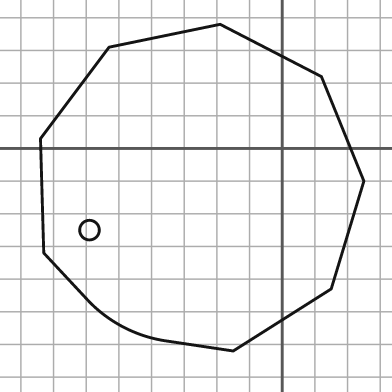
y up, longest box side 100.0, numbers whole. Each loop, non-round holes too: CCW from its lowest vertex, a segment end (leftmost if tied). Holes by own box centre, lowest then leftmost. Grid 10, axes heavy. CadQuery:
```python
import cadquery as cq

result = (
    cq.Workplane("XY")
    .moveTo(-15.0, -62.0)
    .lineTo(15.0, -43.0)
    .lineTo(25.0, -10.0)
    .lineTo(12.0, 22.0)
    .lineTo(-19.0, 38.0)
    .lineTo(-53.0, 31.0)
    .lineTo(-74.0, 3.0)
    .lineTo(-73.0, -32.0)
    .lineTo(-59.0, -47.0)
    .threePointArc((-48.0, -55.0), (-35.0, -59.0))
    .close()
    .moveTo(-59.0, -25.0)
    .circle(3.0)
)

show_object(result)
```